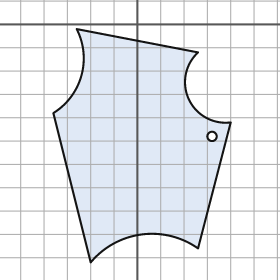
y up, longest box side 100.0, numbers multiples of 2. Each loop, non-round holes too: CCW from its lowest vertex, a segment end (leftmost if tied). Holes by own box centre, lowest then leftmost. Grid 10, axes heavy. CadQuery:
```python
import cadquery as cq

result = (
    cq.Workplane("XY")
    .moveTo(-20.0, -102.0)
    .threePointArc((2.0, -90.0), (26.0, -96.0))
    .lineTo(40.0, -42.0)
    .threePointArc((22.0, -32.0), (26.0, -12.0))
    .lineTo(-26.0, -2.0)
    .threePointArc((-24.0, -22.0), (-36.0, -38.0))
    .close()
    .moveTo(32.0, -48.0)
    .circle(2.0)
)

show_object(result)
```